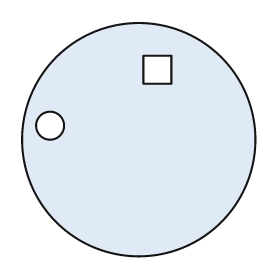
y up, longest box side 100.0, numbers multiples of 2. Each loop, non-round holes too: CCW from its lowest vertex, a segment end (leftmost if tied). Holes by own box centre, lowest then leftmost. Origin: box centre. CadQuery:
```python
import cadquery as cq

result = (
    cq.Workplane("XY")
    .moveTo(0.0, 0.0)
    .circle(50.0)
    .moveTo(-38.0, 6.0)
    .circle(6.0)
    .moveTo(2.0, 24.0)
    .lineTo(14.0, 24.0)
    .lineTo(14.0, 36.0)
    .lineTo(2.0, 36.0)
    .close()
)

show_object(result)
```